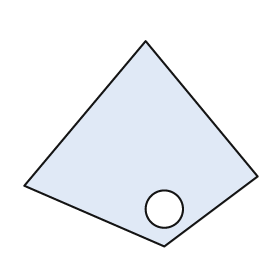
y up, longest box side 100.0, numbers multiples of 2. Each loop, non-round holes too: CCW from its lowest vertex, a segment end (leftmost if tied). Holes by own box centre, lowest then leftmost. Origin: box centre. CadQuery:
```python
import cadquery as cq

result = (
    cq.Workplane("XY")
    .moveTo(10.0, -44.0)
    .lineTo(50.0, -14.0)
    .lineTo(2.0, 44.0)
    .lineTo(-50.0, -18.0)
    .close()
    .moveTo(10.0, -28.0)
    .circle(8.0)
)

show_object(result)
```